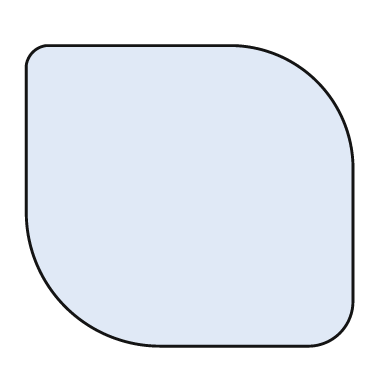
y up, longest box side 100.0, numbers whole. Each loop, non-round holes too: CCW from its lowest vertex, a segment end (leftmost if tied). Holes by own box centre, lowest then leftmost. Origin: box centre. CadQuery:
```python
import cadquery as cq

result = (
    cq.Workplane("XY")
    .moveTo(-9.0, -46.0)
    .lineTo(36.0, -46.0)
    .threePointArc((46.0, -42.0), (50.0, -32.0))
    .lineTo(50.0, 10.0)
    .threePointArc((39.0, 35.0), (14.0, 46.0))
    .lineTo(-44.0, 46.0)
    .threePointArc((-48.0, 44.0), (-50.0, 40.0))
    .lineTo(-50.0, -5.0)
    .threePointArc((-38.0, -34.0), (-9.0, -46.0))
    .close()
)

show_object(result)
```